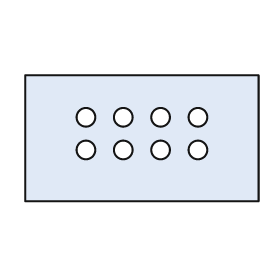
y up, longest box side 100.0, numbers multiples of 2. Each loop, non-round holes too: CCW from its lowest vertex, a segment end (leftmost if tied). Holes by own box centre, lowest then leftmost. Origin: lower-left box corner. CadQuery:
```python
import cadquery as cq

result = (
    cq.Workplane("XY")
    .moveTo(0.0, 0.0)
    .lineTo(100.0, 0.0)
    .lineTo(100.0, 54.0)
    .lineTo(0.0, 54.0)
    .close()
    .moveTo(26.0, 22.0)
    .circle(4.0)
    .moveTo(42.0, 22.0)
    .circle(4.0)
    .moveTo(58.0, 22.0)
    .circle(4.0)
    .moveTo(74.0, 22.0)
    .circle(4.0)
    .moveTo(26.0, 36.0)
    .circle(4.0)
    .moveTo(42.0, 36.0)
    .circle(4.0)
    .moveTo(58.0, 36.0)
    .circle(4.0)
    .moveTo(74.0, 36.0)
    .circle(4.0)
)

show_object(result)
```